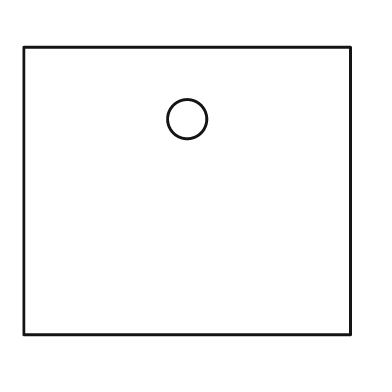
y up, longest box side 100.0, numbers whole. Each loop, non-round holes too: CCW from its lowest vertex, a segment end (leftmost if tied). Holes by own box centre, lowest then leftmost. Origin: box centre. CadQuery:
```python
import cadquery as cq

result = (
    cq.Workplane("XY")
    .moveTo(-50.0, -44.0)
    .lineTo(50.0, -44.0)
    .lineTo(50.0, 44.0)
    .lineTo(-50.0, 44.0)
    .close()
    .moveTo(0.0, 22.0)
    .circle(6.0)
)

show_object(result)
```